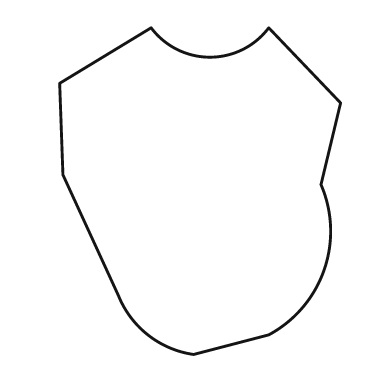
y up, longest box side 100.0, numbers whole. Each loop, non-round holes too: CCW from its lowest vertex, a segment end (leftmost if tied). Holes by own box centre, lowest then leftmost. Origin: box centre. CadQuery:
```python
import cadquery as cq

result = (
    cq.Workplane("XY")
    .moveTo(-2.0, -50.0)
    .lineTo(21.0, -44.0)
    .threePointArc((38.0, -24.0), (37.0, 2.0))
    .lineTo(43.0, 27.0)
    .lineTo(21.0, 50.0)
    .threePointArc((3.0, 41.0), (-15.0, 50.0))
    .lineTo(-43.0, 33.0)
    .lineTo(-42.0, 5.0)
    .lineTo(-25.0, -32.0)
    .threePointArc((-16.0, -44.0), (-2.0, -50.0))
    .close()
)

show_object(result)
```